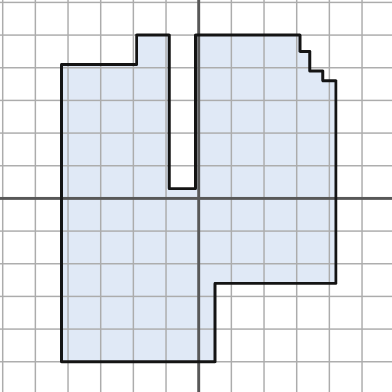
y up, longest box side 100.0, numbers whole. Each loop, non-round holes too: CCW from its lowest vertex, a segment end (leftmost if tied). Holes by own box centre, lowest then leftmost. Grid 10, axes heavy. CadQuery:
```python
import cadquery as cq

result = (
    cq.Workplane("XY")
    .moveTo(-42.0, -50.0)
    .lineTo(5.0, -50.0)
    .lineTo(5.0, -26.0)
    .lineTo(42.0, -26.0)
    .lineTo(42.0, 36.0)
    .lineTo(38.0, 36.0)
    .lineTo(38.0, 39.0)
    .lineTo(34.0, 39.0)
    .lineTo(34.0, 45.0)
    .lineTo(31.0, 45.0)
    .lineTo(31.0, 50.0)
    .lineTo(-1.0, 50.0)
    .lineTo(-1.0, 3.0)
    .lineTo(-9.0, 3.0)
    .lineTo(-9.0, 50.0)
    .lineTo(-19.0, 50.0)
    .lineTo(-19.0, 41.0)
    .lineTo(-42.0, 41.0)
    .close()
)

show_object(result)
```